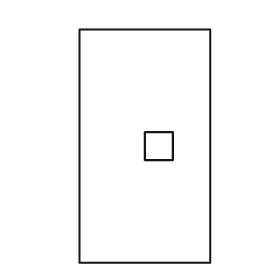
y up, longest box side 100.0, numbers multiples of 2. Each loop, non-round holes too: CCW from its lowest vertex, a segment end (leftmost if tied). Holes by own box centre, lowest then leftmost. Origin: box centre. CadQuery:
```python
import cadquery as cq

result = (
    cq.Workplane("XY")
    .moveTo(-28.0, -50.0)
    .lineTo(28.0, -50.0)
    .lineTo(28.0, 50.0)
    .lineTo(-28.0, 50.0)
    .close()
    .moveTo(0.0, -6.0)
    .lineTo(12.0, -6.0)
    .lineTo(12.0, 6.0)
    .lineTo(0.0, 6.0)
    .close()
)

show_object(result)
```